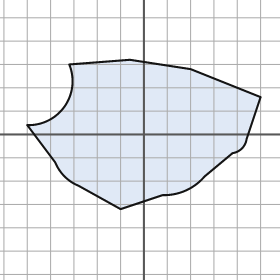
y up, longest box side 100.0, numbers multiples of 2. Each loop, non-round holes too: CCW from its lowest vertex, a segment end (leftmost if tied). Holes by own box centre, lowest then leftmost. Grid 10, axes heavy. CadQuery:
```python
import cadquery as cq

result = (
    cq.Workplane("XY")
    .moveTo(-10.0, -32.0)
    .lineTo(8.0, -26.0)
    .threePointArc((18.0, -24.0), (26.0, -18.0))
    .lineTo(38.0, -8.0)
    .threePointArc((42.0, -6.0), (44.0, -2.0))
    .lineTo(50.0, 16.0)
    .lineTo(20.0, 28.0)
    .lineTo(-6.0, 32.0)
    .lineTo(-32.0, 30.0)
    .threePointArc((-34.0, 12.0), (-50.0, 4.0))
    .lineTo(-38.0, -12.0)
    .threePointArc((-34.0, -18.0), (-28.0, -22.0))
    .close()
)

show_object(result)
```